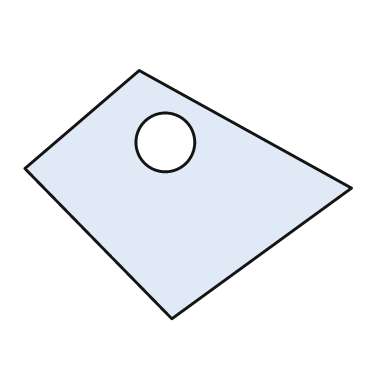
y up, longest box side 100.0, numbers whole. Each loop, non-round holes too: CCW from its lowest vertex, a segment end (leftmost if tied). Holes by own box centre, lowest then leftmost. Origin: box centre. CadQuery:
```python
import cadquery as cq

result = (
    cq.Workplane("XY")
    .moveTo(-5.0, -38.0)
    .lineTo(50.0, 2.0)
    .lineTo(-15.0, 38.0)
    .lineTo(-50.0, 8.0)
    .close()
    .moveTo(-7.0, 16.0)
    .circle(9.0)
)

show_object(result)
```